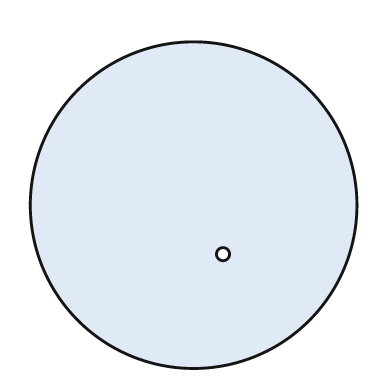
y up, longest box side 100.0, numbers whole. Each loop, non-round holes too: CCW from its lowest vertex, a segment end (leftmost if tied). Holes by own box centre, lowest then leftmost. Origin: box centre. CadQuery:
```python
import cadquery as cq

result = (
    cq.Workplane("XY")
    .moveTo(0.0, 0.0)
    .circle(50.0)
    .moveTo(9.0, -15.0)
    .circle(2.0)
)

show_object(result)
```